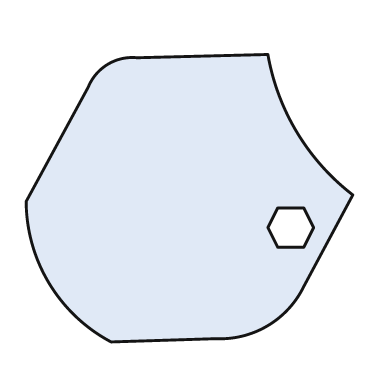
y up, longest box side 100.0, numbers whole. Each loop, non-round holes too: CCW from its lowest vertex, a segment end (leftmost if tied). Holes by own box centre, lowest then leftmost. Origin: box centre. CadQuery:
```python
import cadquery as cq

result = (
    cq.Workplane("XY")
    .moveTo(-24.0, -44.0)
    .lineTo(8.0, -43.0)
    .threePointArc((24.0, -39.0), (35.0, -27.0))
    .lineTo(50.0, 1.0)
    .threePointArc((33.0, 20.0), (24.0, 44.0))
    .lineTo(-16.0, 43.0)
    .threePointArc((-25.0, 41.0), (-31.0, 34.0))
    .lineTo(-50.0, -1.0)
    .threePointArc((-43.0, -26.0), (-24.0, -44.0))
    .close()
    .moveTo(27.0, -15.0)
    .lineTo(35.0, -15.0)
    .lineTo(38.0, -9.0)
    .lineTo(35.0, -3.0)
    .lineTo(27.0, -3.0)
    .lineTo(24.0, -9.0)
    .close()
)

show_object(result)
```